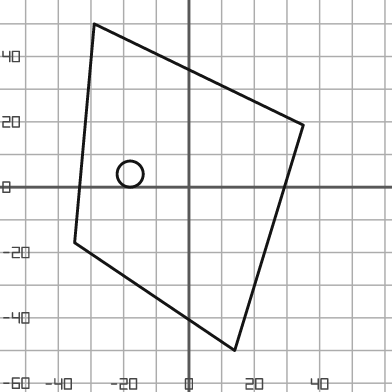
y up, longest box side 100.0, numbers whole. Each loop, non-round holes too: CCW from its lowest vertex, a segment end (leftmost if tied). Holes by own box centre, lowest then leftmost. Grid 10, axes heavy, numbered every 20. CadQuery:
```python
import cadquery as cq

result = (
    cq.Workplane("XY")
    .moveTo(14.0, -50.0)
    .lineTo(35.0, 19.0)
    .lineTo(-29.0, 50.0)
    .lineTo(-35.0, -17.0)
    .close()
    .moveTo(-18.0, 4.0)
    .circle(4.0)
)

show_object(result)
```